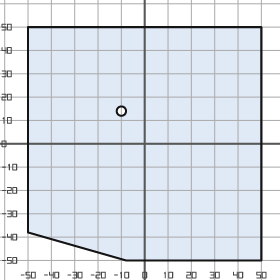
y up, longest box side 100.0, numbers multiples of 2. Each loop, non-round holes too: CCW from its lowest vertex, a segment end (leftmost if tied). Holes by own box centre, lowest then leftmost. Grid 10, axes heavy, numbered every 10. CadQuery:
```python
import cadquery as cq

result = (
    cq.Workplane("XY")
    .moveTo(-8.0, -50.0)
    .lineTo(50.0, -50.0)
    .lineTo(50.0, 50.0)
    .lineTo(-50.0, 50.0)
    .lineTo(-50.0, -38.0)
    .close()
    .moveTo(-10.0, 14.0)
    .circle(2.0)
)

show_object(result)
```